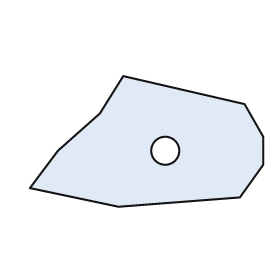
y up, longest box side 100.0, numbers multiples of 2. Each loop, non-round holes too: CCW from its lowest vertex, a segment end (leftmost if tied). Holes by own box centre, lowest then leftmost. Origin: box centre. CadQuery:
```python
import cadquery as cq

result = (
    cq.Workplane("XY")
    .moveTo(-12.0, -28.0)
    .lineTo(40.0, -24.0)
    .lineTo(50.0, -10.0)
    .lineTo(50.0, 2.0)
    .lineTo(42.0, 16.0)
    .lineTo(-10.0, 28.0)
    .lineTo(-20.0, 12.0)
    .lineTo(-38.0, -4.0)
    .lineTo(-50.0, -20.0)
    .close()
    .moveTo(8.0, -4.0)
    .circle(6.0)
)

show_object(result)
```